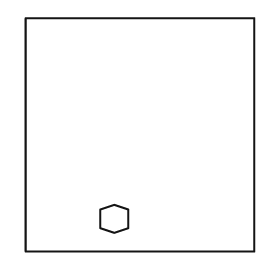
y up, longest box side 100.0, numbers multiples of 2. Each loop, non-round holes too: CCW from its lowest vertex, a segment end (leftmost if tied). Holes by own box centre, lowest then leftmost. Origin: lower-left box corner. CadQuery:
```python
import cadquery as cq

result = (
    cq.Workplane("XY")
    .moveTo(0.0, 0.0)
    .lineTo(98.0, 0.0)
    .lineTo(98.0, 100.0)
    .lineTo(0.0, 100.0)
    .close()
    .moveTo(38.0, 8.0)
    .lineTo(44.0, 10.0)
    .lineTo(44.0, 18.0)
    .lineTo(38.0, 20.0)
    .lineTo(32.0, 18.0)
    .lineTo(32.0, 10.0)
    .close()
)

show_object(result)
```